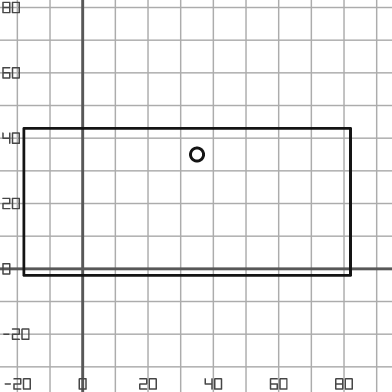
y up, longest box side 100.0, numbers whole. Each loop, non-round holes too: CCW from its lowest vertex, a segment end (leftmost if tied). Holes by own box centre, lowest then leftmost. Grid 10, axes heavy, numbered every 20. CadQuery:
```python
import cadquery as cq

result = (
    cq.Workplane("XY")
    .moveTo(-18.0, -2.0)
    .lineTo(82.0, -2.0)
    .lineTo(82.0, 43.0)
    .lineTo(-18.0, 43.0)
    .close()
    .moveTo(35.0, 35.0)
    .circle(2.0)
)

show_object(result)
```